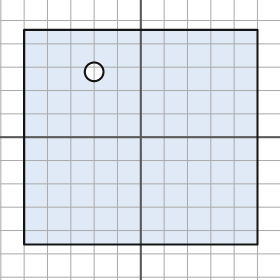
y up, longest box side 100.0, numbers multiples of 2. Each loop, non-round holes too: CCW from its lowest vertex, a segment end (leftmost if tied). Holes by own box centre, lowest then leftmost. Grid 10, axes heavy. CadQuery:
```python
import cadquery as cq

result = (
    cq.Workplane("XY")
    .moveTo(-50.0, -46.0)
    .lineTo(50.0, -46.0)
    .lineTo(50.0, 46.0)
    .lineTo(-50.0, 46.0)
    .close()
    .moveTo(-20.0, 28.0)
    .circle(4.0)
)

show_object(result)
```